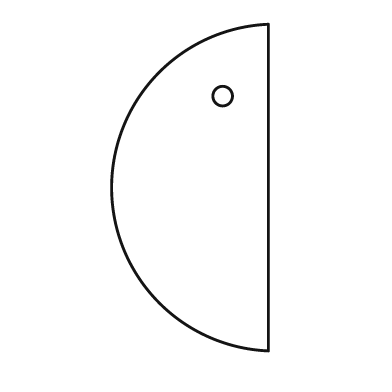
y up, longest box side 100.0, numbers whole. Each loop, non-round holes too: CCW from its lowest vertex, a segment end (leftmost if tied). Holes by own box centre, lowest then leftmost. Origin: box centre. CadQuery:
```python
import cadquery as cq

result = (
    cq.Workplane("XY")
    .moveTo(24.0, -50.0)
    .lineTo(24.0, 50.0)
    .threePointArc((-24.0, 0.0), (24.0, -50.0))
    .close()
    .moveTo(10.0, 28.0)
    .circle(3.0)
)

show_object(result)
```